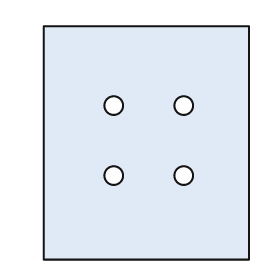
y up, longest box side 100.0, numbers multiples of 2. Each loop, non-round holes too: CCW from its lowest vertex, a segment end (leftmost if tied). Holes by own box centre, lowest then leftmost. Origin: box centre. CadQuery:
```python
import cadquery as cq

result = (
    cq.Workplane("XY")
    .moveTo(-44.0, -50.0)
    .lineTo(44.0, -50.0)
    .lineTo(44.0, 50.0)
    .lineTo(-44.0, 50.0)
    .close()
    .moveTo(-14.0, -14.0)
    .circle(4.0)
    .moveTo(16.0, -14.0)
    .circle(4.0)
    .moveTo(-14.0, 16.0)
    .circle(4.0)
    .moveTo(16.0, 16.0)
    .circle(4.0)
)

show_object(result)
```